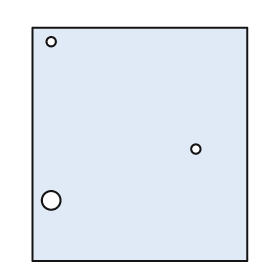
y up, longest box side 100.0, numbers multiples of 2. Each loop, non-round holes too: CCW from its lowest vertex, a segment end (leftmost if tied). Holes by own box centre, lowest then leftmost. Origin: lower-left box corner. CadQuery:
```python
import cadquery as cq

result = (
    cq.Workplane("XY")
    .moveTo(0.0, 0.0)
    .lineTo(92.0, 0.0)
    .lineTo(92.0, 100.0)
    .lineTo(0.0, 100.0)
    .close()
    .moveTo(8.0, 26.0)
    .circle(4.0)
    .moveTo(70.0, 48.0)
    .circle(2.0)
    .moveTo(8.0, 94.0)
    .circle(2.0)
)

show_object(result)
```